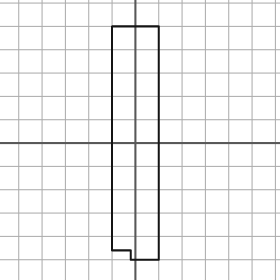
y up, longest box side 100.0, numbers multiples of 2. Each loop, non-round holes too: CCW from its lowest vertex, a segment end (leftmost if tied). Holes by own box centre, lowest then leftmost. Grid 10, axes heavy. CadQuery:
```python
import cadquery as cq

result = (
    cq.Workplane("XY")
    .moveTo(-2.0, -50.0)
    .lineTo(10.0, -50.0)
    .lineTo(10.0, 50.0)
    .lineTo(-10.0, 50.0)
    .lineTo(-10.0, -46.0)
    .lineTo(-2.0, -46.0)
    .close()
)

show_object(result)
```